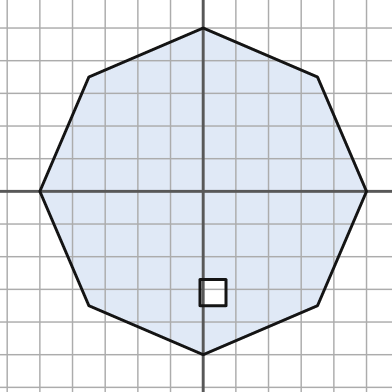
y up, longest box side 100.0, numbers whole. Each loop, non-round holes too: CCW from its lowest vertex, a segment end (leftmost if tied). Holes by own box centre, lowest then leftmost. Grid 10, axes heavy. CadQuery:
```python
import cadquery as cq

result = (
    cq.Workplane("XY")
    .moveTo(0.0, -50.0)
    .lineTo(35.0, -35.0)
    .lineTo(50.0, 0.0)
    .lineTo(35.0, 35.0)
    .lineTo(0.0, 50.0)
    .lineTo(-35.0, 35.0)
    .lineTo(-50.0, 0.0)
    .lineTo(-35.0, -35.0)
    .close()
    .moveTo(-1.0, -35.0)
    .lineTo(7.0, -35.0)
    .lineTo(7.0, -27.0)
    .lineTo(-1.0, -27.0)
    .close()
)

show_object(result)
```